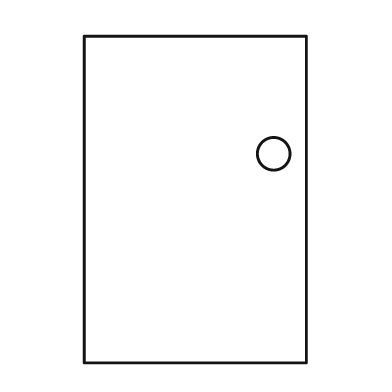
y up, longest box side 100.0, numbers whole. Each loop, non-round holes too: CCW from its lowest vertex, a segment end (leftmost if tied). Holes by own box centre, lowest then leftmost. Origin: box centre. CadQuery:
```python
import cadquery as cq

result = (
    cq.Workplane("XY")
    .moveTo(-34.0, -50.0)
    .lineTo(34.0, -50.0)
    .lineTo(34.0, 50.0)
    .lineTo(-34.0, 50.0)
    .close()
    .moveTo(24.0, 14.0)
    .circle(5.0)
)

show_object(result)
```